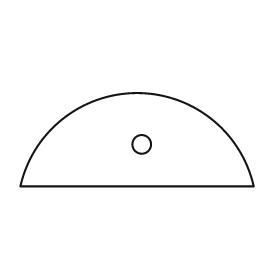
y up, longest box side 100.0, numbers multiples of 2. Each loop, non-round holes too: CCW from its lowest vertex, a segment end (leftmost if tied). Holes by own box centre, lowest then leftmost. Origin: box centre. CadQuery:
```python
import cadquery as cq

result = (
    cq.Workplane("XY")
    .moveTo(-50.0, -20.0)
    .lineTo(50.0, -20.0)
    .threePointArc((0.0, 20.0), (-50.0, -20.0))
    .close()
    .moveTo(2.0, -2.0)
    .circle(4.0)
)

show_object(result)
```